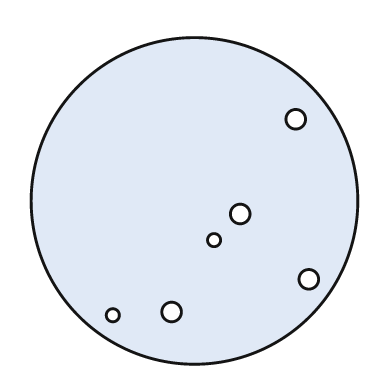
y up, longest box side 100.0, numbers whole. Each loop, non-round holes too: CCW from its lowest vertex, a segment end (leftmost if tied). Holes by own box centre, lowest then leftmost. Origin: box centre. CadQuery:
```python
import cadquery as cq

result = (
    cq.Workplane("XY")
    .moveTo(0.0, 0.0)
    .circle(50.0)
    .moveTo(-25.0, -35.0)
    .circle(2.0)
    .moveTo(-7.0, -34.0)
    .circle(3.0)
    .moveTo(35.0, -24.0)
    .circle(3.0)
    .moveTo(6.0, -12.0)
    .circle(2.0)
    .moveTo(14.0, -4.0)
    .circle(3.0)
    .moveTo(31.0, 25.0)
    .circle(3.0)
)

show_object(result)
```